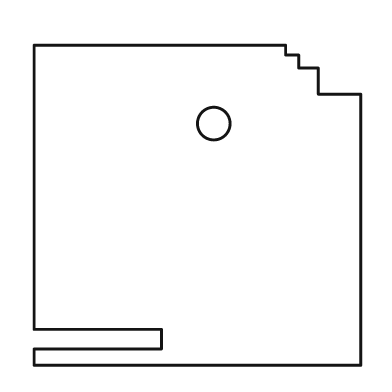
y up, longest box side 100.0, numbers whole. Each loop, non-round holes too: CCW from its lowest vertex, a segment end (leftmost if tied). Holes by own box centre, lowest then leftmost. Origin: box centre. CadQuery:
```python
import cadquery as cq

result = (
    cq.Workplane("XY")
    .moveTo(-50.0, -49.0)
    .lineTo(50.0, -49.0)
    .lineTo(50.0, 34.0)
    .lineTo(37.0, 34.0)
    .lineTo(37.0, 42.0)
    .lineTo(31.0, 42.0)
    .lineTo(31.0, 46.0)
    .lineTo(27.0, 46.0)
    .lineTo(27.0, 49.0)
    .lineTo(-50.0, 49.0)
    .lineTo(-50.0, -38.0)
    .lineTo(-11.0, -38.0)
    .lineTo(-11.0, -44.0)
    .lineTo(-50.0, -44.0)
    .close()
    .moveTo(5.0, 25.0)
    .circle(5.0)
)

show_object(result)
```